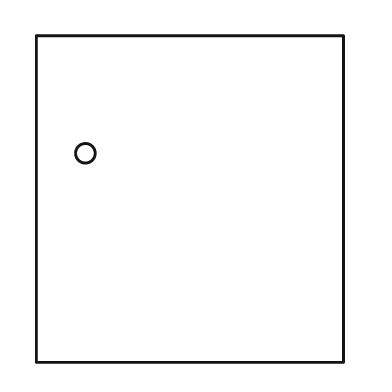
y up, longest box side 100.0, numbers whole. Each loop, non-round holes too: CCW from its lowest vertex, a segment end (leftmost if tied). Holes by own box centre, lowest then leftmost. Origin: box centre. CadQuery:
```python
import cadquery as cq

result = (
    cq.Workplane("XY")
    .moveTo(-47.0, -50.0)
    .lineTo(47.0, -50.0)
    .lineTo(47.0, 50.0)
    .lineTo(-47.0, 50.0)
    .close()
    .moveTo(-32.0, 14.0)
    .circle(3.0)
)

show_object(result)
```